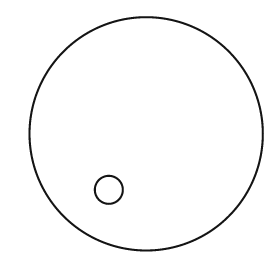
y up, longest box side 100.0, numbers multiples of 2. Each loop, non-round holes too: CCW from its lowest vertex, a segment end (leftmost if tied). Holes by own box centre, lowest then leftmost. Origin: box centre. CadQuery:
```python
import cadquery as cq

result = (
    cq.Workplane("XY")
    .moveTo(0.0, 0.0)
    .circle(50.0)
    .moveTo(-16.0, -24.0)
    .circle(6.0)
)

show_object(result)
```